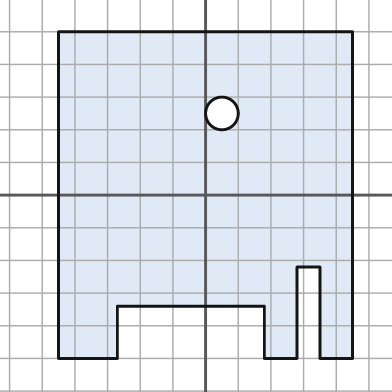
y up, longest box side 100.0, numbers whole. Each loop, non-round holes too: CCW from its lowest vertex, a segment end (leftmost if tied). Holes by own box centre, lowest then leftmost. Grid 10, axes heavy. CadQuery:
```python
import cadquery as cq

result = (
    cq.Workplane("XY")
    .moveTo(-45.0, -50.0)
    .lineTo(-27.0, -50.0)
    .lineTo(-27.0, -34.0)
    .lineTo(18.0, -34.0)
    .lineTo(18.0, -50.0)
    .lineTo(28.0, -50.0)
    .lineTo(28.0, -22.0)
    .lineTo(35.0, -22.0)
    .lineTo(35.0, -50.0)
    .lineTo(45.0, -50.0)
    .lineTo(45.0, 50.0)
    .lineTo(-45.0, 50.0)
    .close()
    .moveTo(5.0, 25.0)
    .circle(5.0)
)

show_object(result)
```